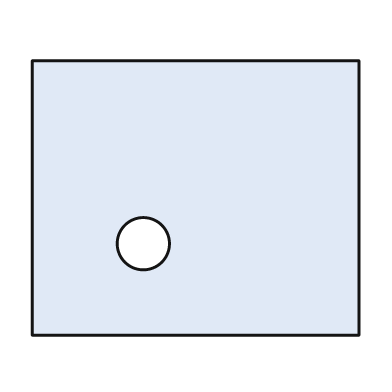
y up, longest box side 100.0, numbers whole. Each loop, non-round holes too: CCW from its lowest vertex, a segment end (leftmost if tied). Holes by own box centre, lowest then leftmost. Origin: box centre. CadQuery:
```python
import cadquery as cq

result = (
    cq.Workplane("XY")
    .moveTo(-50.0, -42.0)
    .lineTo(50.0, -42.0)
    .lineTo(50.0, 42.0)
    .lineTo(-50.0, 42.0)
    .close()
    .moveTo(-16.0, -14.0)
    .circle(8.0)
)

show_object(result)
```